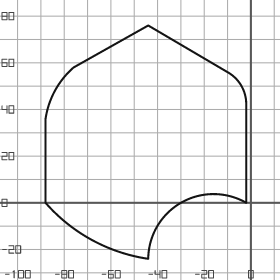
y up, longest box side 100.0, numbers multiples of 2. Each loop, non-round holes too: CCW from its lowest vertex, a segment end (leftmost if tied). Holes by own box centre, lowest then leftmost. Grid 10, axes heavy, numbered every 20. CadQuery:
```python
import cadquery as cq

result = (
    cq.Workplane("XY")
    .moveTo(-44.0, -24.0)
    .threePointArc((-30.0, 0.0), (-2.0, 0.0))
    .lineTo(-2.0, 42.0)
    .threePointArc((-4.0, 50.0), (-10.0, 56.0))
    .lineTo(-44.0, 76.0)
    .lineTo(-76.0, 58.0)
    .threePointArc((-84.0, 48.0), (-88.0, 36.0))
    .lineTo(-88.0, 0.0)
    .threePointArc((-68.0, -16.0), (-44.0, -24.0))
    .close()
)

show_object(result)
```